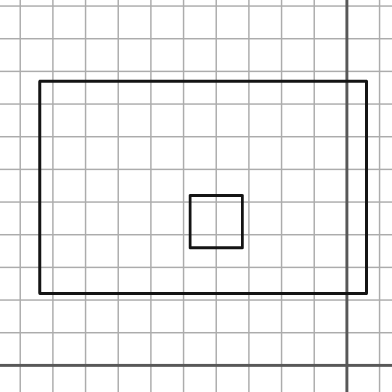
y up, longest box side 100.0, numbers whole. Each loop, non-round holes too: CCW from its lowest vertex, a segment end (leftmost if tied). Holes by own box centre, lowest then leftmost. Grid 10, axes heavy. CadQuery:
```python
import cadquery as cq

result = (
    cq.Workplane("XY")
    .moveTo(-94.0, 22.0)
    .lineTo(6.0, 22.0)
    .lineTo(6.0, 87.0)
    .lineTo(-94.0, 87.0)
    .close()
    .moveTo(-48.0, 36.0)
    .lineTo(-32.0, 36.0)
    .lineTo(-32.0, 52.0)
    .lineTo(-48.0, 52.0)
    .close()
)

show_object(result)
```